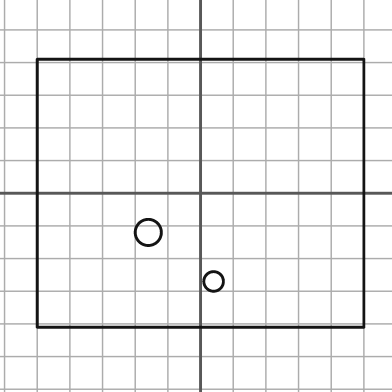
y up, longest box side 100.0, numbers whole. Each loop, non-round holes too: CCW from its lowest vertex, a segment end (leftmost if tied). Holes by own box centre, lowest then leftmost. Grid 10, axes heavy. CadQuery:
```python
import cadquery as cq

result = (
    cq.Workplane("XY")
    .moveTo(-50.0, -41.0)
    .lineTo(50.0, -41.0)
    .lineTo(50.0, 41.0)
    .lineTo(-50.0, 41.0)
    .close()
    .moveTo(4.0, -27.0)
    .circle(3.0)
    .moveTo(-16.0, -12.0)
    .circle(4.0)
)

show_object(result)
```